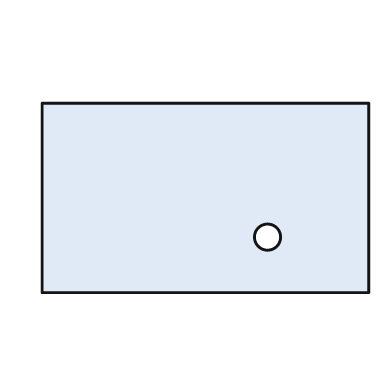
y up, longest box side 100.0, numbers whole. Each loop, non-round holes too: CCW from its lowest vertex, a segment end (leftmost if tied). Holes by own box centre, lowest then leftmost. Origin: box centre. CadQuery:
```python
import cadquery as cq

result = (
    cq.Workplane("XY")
    .moveTo(-50.0, -29.0)
    .lineTo(50.0, -29.0)
    .lineTo(50.0, 29.0)
    .lineTo(-50.0, 29.0)
    .close()
    .moveTo(19.0, -12.0)
    .circle(4.0)
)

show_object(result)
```